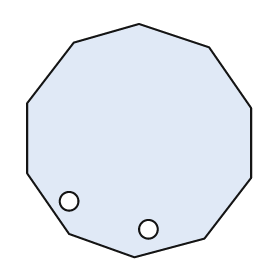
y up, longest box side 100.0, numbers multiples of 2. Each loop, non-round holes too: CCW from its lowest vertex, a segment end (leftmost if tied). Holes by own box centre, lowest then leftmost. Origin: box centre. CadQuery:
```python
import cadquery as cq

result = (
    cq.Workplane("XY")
    .moveTo(-2.0, -50.0)
    .lineTo(28.0, -42.0)
    .lineTo(48.0, -16.0)
    .lineTo(48.0, 14.0)
    .lineTo(30.0, 40.0)
    .lineTo(0.0, 50.0)
    .lineTo(-28.0, 42.0)
    .lineTo(-48.0, 16.0)
    .lineTo(-48.0, -14.0)
    .lineTo(-30.0, -40.0)
    .close()
    .moveTo(4.0, -38.0)
    .circle(4.0)
    .moveTo(-30.0, -26.0)
    .circle(4.0)
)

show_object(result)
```